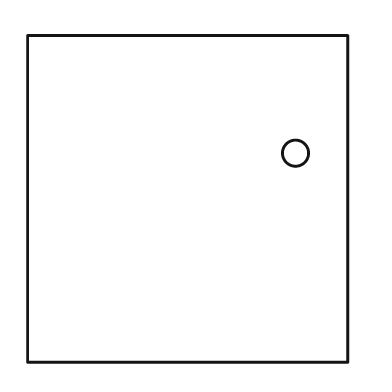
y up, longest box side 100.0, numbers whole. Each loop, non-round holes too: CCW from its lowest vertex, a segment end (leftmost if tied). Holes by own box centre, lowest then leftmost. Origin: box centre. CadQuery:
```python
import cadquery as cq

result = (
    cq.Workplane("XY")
    .moveTo(-49.0, -50.0)
    .lineTo(49.0, -50.0)
    .lineTo(49.0, 50.0)
    .lineTo(-49.0, 50.0)
    .close()
    .moveTo(33.0, 14.0)
    .circle(4.0)
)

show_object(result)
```